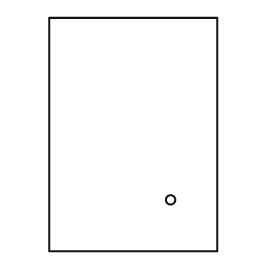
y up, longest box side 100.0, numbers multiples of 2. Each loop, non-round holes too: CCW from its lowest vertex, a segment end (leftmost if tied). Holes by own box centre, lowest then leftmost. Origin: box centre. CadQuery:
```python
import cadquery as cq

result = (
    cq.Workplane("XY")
    .moveTo(-36.0, -50.0)
    .lineTo(36.0, -50.0)
    .lineTo(36.0, 50.0)
    .lineTo(-36.0, 50.0)
    .close()
    .moveTo(16.0, -28.0)
    .circle(2.0)
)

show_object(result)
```